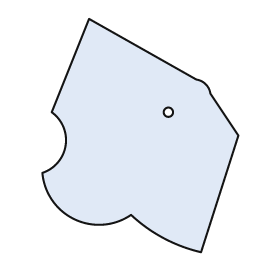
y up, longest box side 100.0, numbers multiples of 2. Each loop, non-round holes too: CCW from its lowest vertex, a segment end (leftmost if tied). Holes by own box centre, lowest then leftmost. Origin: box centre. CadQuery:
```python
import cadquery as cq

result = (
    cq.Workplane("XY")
    .moveTo(26.0, -50.0)
    .lineTo(42.0, 0.0)
    .lineTo(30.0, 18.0)
    .threePointArc((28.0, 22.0), (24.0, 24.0))
    .lineTo(-22.0, 50.0)
    .lineTo(-38.0, 10.0)
    .threePointArc((-32.0, -4.0), (-42.0, -16.0))
    .threePointArc((-28.0, -36.0), (-4.0, -34.0))
    .threePointArc((10.0, -44.0), (26.0, -50.0))
    .close()
    .moveTo(12.0, 10.0)
    .circle(2.0)
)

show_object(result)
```